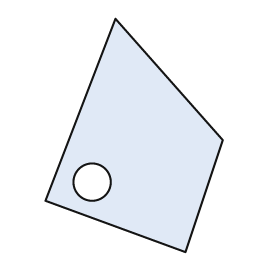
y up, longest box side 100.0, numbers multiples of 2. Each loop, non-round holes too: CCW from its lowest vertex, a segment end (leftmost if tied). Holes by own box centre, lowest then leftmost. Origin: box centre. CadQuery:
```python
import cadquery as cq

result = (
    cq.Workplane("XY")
    .moveTo(22.0, -50.0)
    .lineTo(38.0, -2.0)
    .lineTo(-8.0, 50.0)
    .lineTo(-38.0, -28.0)
    .close()
    .moveTo(-18.0, -20.0)
    .circle(8.0)
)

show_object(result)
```